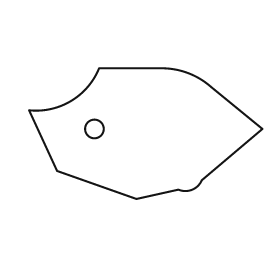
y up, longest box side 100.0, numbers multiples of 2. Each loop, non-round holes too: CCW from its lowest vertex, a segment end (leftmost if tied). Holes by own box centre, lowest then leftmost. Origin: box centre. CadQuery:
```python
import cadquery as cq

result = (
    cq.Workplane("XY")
    .moveTo(-4.0, -28.0)
    .lineTo(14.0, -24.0)
    .threePointArc((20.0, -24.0), (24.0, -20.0))
    .lineTo(50.0, 2.0)
    .lineTo(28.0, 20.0)
    .threePointArc((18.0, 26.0), (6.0, 28.0))
    .lineTo(-20.0, 28.0)
    .threePointArc((-32.0, 14.0), (-50.0, 10.0))
    .lineTo(-38.0, -16.0)
    .close()
    .moveTo(-22.0, 2.0)
    .circle(4.0)
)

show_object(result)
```